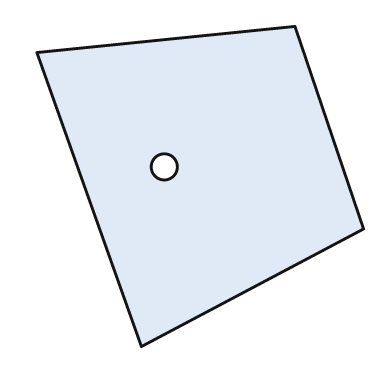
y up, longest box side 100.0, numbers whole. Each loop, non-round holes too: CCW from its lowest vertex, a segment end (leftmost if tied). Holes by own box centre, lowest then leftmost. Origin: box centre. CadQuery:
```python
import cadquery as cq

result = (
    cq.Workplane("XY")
    .moveTo(-18.0, -49.0)
    .lineTo(50.0, -13.0)
    .lineTo(29.0, 49.0)
    .lineTo(-50.0, 41.0)
    .close()
    .moveTo(-11.0, 6.0)
    .circle(4.0)
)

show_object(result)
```